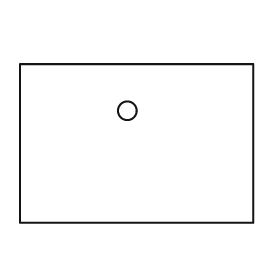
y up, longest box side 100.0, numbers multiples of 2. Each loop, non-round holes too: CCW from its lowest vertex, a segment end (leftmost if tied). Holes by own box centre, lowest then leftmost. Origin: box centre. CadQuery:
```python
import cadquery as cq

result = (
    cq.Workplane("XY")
    .moveTo(-50.0, -34.0)
    .lineTo(50.0, -34.0)
    .lineTo(50.0, 34.0)
    .lineTo(-50.0, 34.0)
    .close()
    .moveTo(-4.0, 14.0)
    .circle(4.0)
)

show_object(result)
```